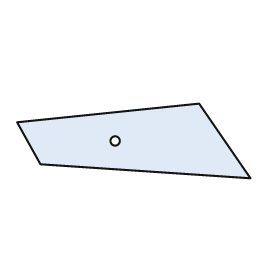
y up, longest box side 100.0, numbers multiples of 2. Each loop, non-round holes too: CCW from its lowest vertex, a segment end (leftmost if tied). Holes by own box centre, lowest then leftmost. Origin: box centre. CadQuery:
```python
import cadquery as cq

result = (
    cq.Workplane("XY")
    .moveTo(50.0, -16.0)
    .lineTo(28.0, 16.0)
    .lineTo(-50.0, 8.0)
    .lineTo(-40.0, -10.0)
    .close()
    .moveTo(-8.0, 0.0)
    .circle(2.0)
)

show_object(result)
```